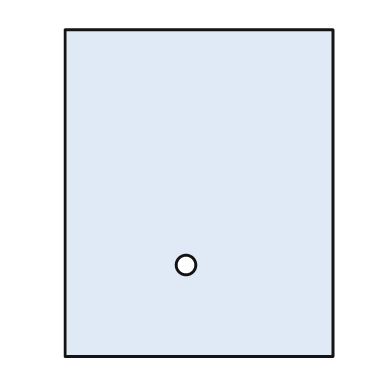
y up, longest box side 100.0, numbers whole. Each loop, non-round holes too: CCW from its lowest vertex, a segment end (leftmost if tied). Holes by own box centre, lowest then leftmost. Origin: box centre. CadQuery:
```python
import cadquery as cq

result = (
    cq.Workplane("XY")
    .moveTo(-41.0, -50.0)
    .lineTo(41.0, -50.0)
    .lineTo(41.0, 50.0)
    .lineTo(-41.0, 50.0)
    .close()
    .moveTo(-4.0, -22.0)
    .circle(3.0)
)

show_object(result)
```